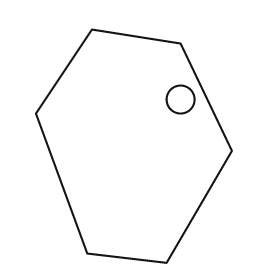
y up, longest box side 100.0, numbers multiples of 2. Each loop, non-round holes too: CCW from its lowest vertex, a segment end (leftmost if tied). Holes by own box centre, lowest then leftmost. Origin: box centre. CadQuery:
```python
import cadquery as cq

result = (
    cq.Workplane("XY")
    .moveTo(14.0, -50.0)
    .lineTo(42.0, -2.0)
    .lineTo(20.0, 44.0)
    .lineTo(-18.0, 50.0)
    .lineTo(-42.0, 14.0)
    .lineTo(-20.0, -46.0)
    .close()
    .moveTo(20.0, 20.0)
    .circle(6.0)
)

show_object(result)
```